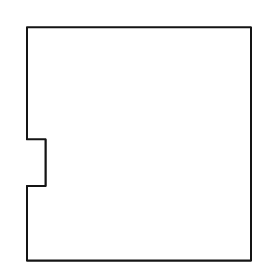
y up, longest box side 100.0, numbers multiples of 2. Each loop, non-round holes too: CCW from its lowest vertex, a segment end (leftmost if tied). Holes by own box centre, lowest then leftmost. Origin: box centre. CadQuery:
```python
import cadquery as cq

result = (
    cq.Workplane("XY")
    .moveTo(-48.0, -50.0)
    .lineTo(48.0, -50.0)
    .lineTo(48.0, 50.0)
    .lineTo(-48.0, 50.0)
    .lineTo(-48.0, 2.0)
    .lineTo(-40.0, 2.0)
    .lineTo(-40.0, -18.0)
    .lineTo(-48.0, -18.0)
    .close()
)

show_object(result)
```